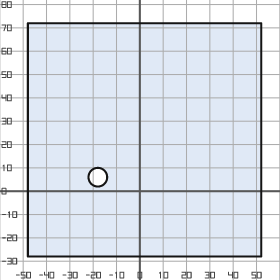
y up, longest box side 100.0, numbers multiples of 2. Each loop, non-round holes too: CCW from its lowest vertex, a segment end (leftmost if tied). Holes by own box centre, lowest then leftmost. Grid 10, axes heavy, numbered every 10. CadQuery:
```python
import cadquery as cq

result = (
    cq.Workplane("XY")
    .moveTo(-48.0, -28.0)
    .lineTo(52.0, -28.0)
    .lineTo(52.0, 72.0)
    .lineTo(-48.0, 72.0)
    .close()
    .moveTo(-18.0, 6.0)
    .circle(4.0)
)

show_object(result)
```